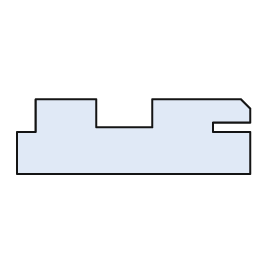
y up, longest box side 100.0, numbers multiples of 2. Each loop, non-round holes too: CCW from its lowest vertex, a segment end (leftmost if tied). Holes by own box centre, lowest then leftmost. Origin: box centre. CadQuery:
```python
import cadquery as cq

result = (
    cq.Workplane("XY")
    .moveTo(-50.0, -16.0)
    .lineTo(50.0, -16.0)
    .lineTo(50.0, 2.0)
    .lineTo(34.0, 2.0)
    .lineTo(34.0, 6.0)
    .lineTo(50.0, 6.0)
    .lineTo(50.0, 12.0)
    .lineTo(46.0, 16.0)
    .lineTo(8.0, 16.0)
    .lineTo(8.0, 4.0)
    .lineTo(-16.0, 4.0)
    .lineTo(-16.0, 16.0)
    .lineTo(-42.0, 16.0)
    .lineTo(-42.0, 2.0)
    .lineTo(-50.0, 2.0)
    .close()
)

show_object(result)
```